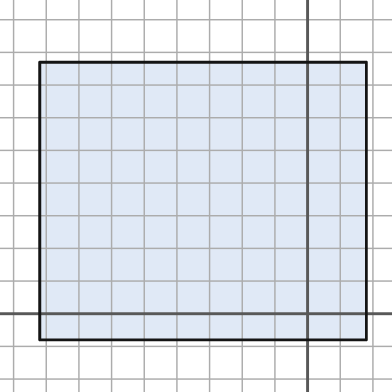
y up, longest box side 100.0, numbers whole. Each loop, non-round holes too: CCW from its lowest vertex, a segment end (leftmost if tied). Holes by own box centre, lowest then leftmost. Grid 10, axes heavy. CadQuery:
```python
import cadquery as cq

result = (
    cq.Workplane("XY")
    .moveTo(-82.0, -8.0)
    .lineTo(18.0, -8.0)
    .lineTo(18.0, 77.0)
    .lineTo(-82.0, 77.0)
    .close()
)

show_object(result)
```